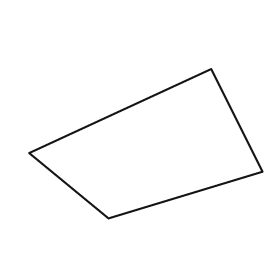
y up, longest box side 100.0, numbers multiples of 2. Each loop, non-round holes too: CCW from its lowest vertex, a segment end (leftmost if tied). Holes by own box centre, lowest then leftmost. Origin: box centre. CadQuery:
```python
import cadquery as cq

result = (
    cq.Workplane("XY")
    .moveTo(-16.0, -32.0)
    .lineTo(50.0, -12.0)
    .lineTo(28.0, 32.0)
    .lineTo(-50.0, -4.0)
    .close()
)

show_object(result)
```